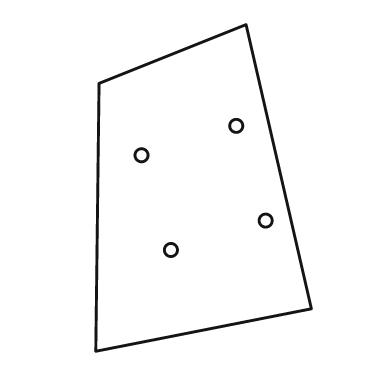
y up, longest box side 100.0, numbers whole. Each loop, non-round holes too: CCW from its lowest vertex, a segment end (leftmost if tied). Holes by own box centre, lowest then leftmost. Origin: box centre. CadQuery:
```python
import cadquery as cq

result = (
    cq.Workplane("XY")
    .moveTo(-33.0, -50.0)
    .lineTo(33.0, -37.0)
    .lineTo(13.0, 50.0)
    .lineTo(-32.0, 32.0)
    .close()
    .moveTo(-10.0, -19.0)
    .circle(2.0)
    .moveTo(19.0, -10.0)
    .circle(2.0)
    .moveTo(-19.0, 10.0)
    .circle(2.0)
    .moveTo(10.0, 19.0)
    .circle(2.0)
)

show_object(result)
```